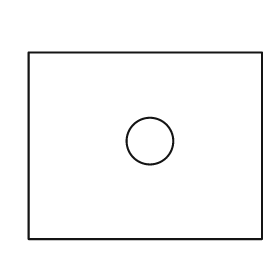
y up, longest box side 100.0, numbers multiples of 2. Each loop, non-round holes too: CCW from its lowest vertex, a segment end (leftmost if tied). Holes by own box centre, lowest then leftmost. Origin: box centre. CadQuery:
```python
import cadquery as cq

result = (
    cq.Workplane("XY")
    .moveTo(-50.0, -40.0)
    .lineTo(50.0, -40.0)
    .lineTo(50.0, 40.0)
    .lineTo(-50.0, 40.0)
    .close()
    .moveTo(2.0, 2.0)
    .circle(10.0)
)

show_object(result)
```